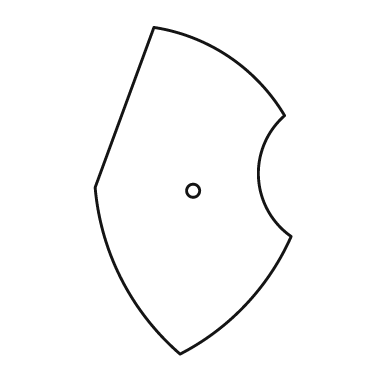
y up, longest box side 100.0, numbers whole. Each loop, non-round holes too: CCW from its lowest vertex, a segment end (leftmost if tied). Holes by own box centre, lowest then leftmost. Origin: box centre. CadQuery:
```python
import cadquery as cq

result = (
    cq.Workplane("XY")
    .moveTo(-4.0, -50.0)
    .threePointArc((16.0, -35.0), (30.0, -14.0))
    .threePointArc((20.0, 4.0), (28.0, 23.0))
    .threePointArc((11.0, 41.0), (-12.0, 50.0))
    .lineTo(-30.0, 1.0)
    .threePointArc((-22.0, -27.0), (-4.0, -50.0))
    .close()
    .moveTo(0.0, 0.0)
    .circle(2.0)
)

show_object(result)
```